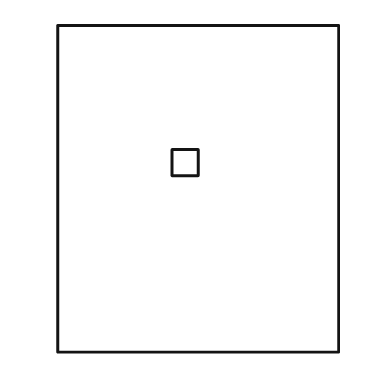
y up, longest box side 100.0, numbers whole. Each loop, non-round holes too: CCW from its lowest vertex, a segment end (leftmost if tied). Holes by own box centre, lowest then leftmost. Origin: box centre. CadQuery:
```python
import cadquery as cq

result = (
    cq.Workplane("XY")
    .moveTo(-43.0, -50.0)
    .lineTo(43.0, -50.0)
    .lineTo(43.0, 50.0)
    .lineTo(-43.0, 50.0)
    .close()
    .moveTo(-8.0, 4.0)
    .lineTo(0.0, 4.0)
    .lineTo(0.0, 12.0)
    .lineTo(-8.0, 12.0)
    .close()
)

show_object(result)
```